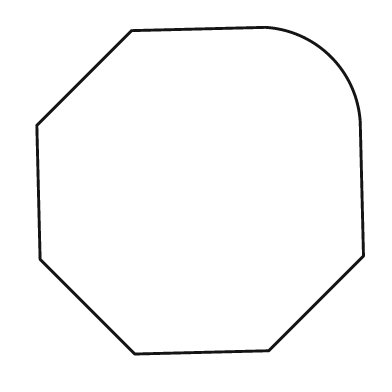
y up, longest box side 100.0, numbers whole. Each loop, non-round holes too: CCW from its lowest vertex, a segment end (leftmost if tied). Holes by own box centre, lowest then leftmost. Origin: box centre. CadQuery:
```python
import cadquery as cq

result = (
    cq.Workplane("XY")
    .moveTo(-20.0, -50.0)
    .lineTo(21.0, -49.0)
    .lineTo(50.0, -20.0)
    .lineTo(49.0, 21.0)
    .threePointArc((40.0, 41.0), (20.0, 50.0))
    .lineTo(-21.0, 49.0)
    .lineTo(-50.0, 20.0)
    .lineTo(-49.0, -21.0)
    .close()
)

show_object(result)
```